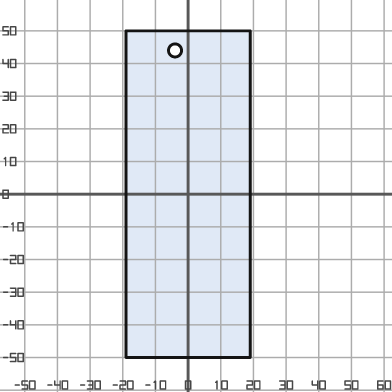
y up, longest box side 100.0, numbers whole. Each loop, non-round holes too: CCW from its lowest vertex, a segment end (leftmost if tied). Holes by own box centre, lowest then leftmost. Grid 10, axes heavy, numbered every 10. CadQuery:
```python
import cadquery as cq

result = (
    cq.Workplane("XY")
    .moveTo(-19.0, -50.0)
    .lineTo(19.0, -50.0)
    .lineTo(19.0, 50.0)
    .lineTo(-19.0, 50.0)
    .close()
    .moveTo(-4.0, 44.0)
    .circle(2.0)
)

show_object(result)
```